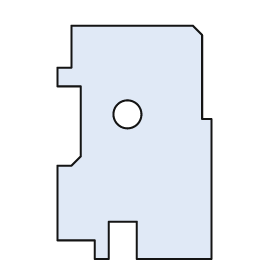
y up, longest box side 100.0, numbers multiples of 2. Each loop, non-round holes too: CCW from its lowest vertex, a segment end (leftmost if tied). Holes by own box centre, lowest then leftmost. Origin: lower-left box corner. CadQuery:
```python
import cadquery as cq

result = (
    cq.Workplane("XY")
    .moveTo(16.0, 0.0)
    .lineTo(22.0, 0.0)
    .lineTo(22.0, 16.0)
    .lineTo(34.0, 16.0)
    .lineTo(34.0, 0.0)
    .lineTo(66.0, 0.0)
    .lineTo(66.0, 60.0)
    .lineTo(62.0, 60.0)
    .lineTo(62.0, 96.0)
    .lineTo(58.0, 100.0)
    .lineTo(6.0, 100.0)
    .lineTo(6.0, 82.0)
    .lineTo(0.0, 82.0)
    .lineTo(0.0, 74.0)
    .lineTo(10.0, 74.0)
    .lineTo(10.0, 44.0)
    .lineTo(6.0, 40.0)
    .lineTo(0.0, 40.0)
    .lineTo(0.0, 8.0)
    .lineTo(16.0, 8.0)
    .close()
    .moveTo(30.0, 62.0)
    .circle(6.0)
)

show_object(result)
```